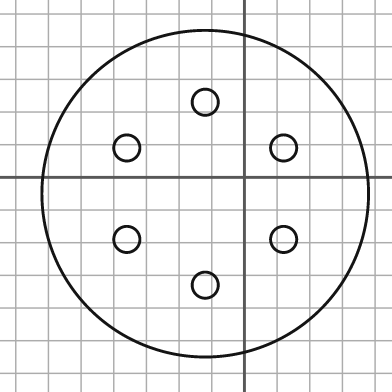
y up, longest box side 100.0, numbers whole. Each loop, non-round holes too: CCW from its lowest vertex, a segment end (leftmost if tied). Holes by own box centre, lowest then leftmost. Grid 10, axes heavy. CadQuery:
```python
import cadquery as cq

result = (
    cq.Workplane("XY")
    .moveTo(-12.0, -5.0)
    .circle(50.0)
    .moveTo(-12.0, -33.0)
    .circle(4.0)
    .moveTo(-36.0, -19.0)
    .circle(4.0)
    .moveTo(12.0, -19.0)
    .circle(4.0)
    .moveTo(-36.0, 9.0)
    .circle(4.0)
    .moveTo(12.0, 9.0)
    .circle(4.0)
    .moveTo(-12.0, 23.0)
    .circle(4.0)
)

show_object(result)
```